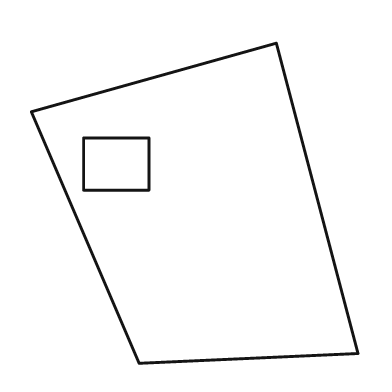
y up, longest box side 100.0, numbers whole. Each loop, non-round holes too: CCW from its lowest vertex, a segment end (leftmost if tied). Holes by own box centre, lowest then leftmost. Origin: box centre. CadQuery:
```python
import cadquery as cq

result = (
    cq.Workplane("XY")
    .moveTo(-17.0, -49.0)
    .lineTo(50.0, -46.0)
    .lineTo(25.0, 49.0)
    .lineTo(-50.0, 28.0)
    .close()
    .moveTo(-34.0, 4.0)
    .lineTo(-14.0, 4.0)
    .lineTo(-14.0, 20.0)
    .lineTo(-34.0, 20.0)
    .close()
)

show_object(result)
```